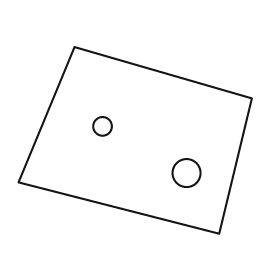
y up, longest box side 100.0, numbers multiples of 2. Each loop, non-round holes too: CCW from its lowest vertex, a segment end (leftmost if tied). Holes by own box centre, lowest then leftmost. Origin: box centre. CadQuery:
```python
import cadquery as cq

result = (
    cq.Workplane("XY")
    .moveTo(36.0, -40.0)
    .lineTo(50.0, 18.0)
    .lineTo(-26.0, 40.0)
    .lineTo(-50.0, -18.0)
    .close()
    .moveTo(22.0, -14.0)
    .circle(6.0)
    .moveTo(-14.0, 6.0)
    .circle(4.0)
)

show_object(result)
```